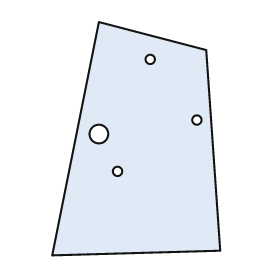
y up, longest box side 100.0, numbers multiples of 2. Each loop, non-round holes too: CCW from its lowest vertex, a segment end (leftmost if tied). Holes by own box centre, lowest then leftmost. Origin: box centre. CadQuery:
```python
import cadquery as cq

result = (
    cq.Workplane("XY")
    .moveTo(-36.0, -50.0)
    .lineTo(36.0, -48.0)
    .lineTo(30.0, 38.0)
    .lineTo(-16.0, 50.0)
    .close()
    .moveTo(-8.0, -14.0)
    .circle(2.0)
    .moveTo(-16.0, 2.0)
    .circle(4.0)
    .moveTo(26.0, 8.0)
    .circle(2.0)
    .moveTo(6.0, 34.0)
    .circle(2.0)
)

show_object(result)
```